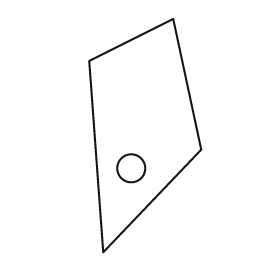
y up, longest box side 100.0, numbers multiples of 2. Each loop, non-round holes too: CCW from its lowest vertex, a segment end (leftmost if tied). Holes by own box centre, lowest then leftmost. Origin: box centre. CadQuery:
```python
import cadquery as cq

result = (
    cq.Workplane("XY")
    .moveTo(-18.0, -50.0)
    .lineTo(24.0, -6.0)
    .lineTo(12.0, 50.0)
    .lineTo(-24.0, 32.0)
    .close()
    .moveTo(-6.0, -14.0)
    .circle(6.0)
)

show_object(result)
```